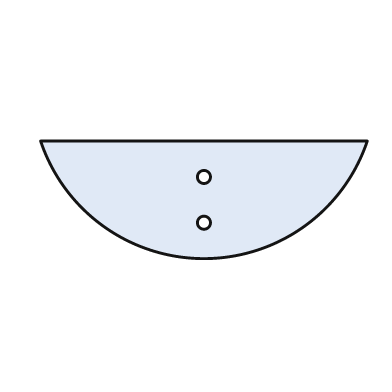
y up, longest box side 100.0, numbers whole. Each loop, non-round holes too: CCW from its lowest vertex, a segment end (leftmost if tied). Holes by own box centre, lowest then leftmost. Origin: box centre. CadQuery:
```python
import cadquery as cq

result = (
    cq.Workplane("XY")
    .moveTo(-50.0, 18.0)
    .threePointArc((0.0, -18.0), (50.0, 18.0))
    .close()
    .moveTo(0.0, -7.0)
    .circle(2.0)
    .moveTo(0.0, 7.0)
    .circle(2.0)
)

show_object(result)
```